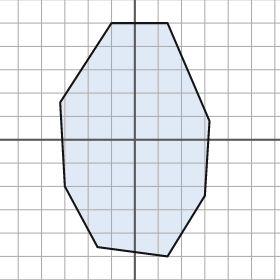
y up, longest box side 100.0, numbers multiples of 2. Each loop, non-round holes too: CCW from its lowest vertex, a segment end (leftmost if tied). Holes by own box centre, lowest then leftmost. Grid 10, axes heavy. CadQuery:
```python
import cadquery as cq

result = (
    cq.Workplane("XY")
    .moveTo(14.0, -50.0)
    .lineTo(30.0, -24.0)
    .lineTo(32.0, 8.0)
    .lineTo(14.0, 50.0)
    .lineTo(-10.0, 50.0)
    .lineTo(-32.0, 16.0)
    .lineTo(-30.0, -20.0)
    .lineTo(-16.0, -46.0)
    .close()
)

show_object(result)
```